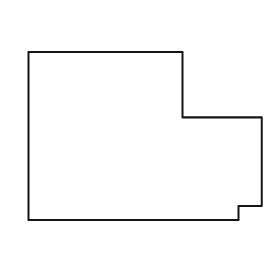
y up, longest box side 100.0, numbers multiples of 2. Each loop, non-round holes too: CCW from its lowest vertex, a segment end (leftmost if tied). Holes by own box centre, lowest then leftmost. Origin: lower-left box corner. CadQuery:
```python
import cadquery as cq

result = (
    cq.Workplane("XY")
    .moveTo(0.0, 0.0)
    .lineTo(90.0, 0.0)
    .lineTo(90.0, 6.0)
    .lineTo(100.0, 6.0)
    .lineTo(100.0, 44.0)
    .lineTo(66.0, 44.0)
    .lineTo(66.0, 72.0)
    .lineTo(0.0, 72.0)
    .close()
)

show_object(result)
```